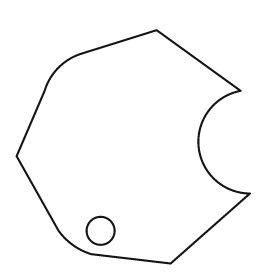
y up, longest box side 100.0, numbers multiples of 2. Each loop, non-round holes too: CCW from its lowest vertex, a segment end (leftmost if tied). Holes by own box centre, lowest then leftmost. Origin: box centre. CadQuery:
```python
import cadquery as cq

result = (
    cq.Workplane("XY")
    .moveTo(16.0, -50.0)
    .lineTo(50.0, -20.0)
    .threePointArc((28.0, 0.0), (46.0, 24.0))
    .lineTo(10.0, 50.0)
    .lineTo(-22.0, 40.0)
    .threePointArc((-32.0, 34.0), (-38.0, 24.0))
    .lineTo(-50.0, -4.0)
    .lineTo(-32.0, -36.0)
    .threePointArc((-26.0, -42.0), (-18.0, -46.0))
    .close()
    .moveTo(-14.0, -36.0)
    .circle(6.0)
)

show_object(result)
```